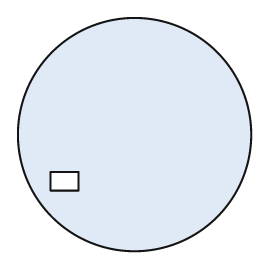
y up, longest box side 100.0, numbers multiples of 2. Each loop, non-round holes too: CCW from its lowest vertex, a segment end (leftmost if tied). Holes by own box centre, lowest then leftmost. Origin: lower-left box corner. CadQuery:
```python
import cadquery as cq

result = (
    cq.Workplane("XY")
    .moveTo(50.0, 50.0)
    .circle(50.0)
    .moveTo(14.0, 26.0)
    .lineTo(26.0, 26.0)
    .lineTo(26.0, 34.0)
    .lineTo(14.0, 34.0)
    .close()
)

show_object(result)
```